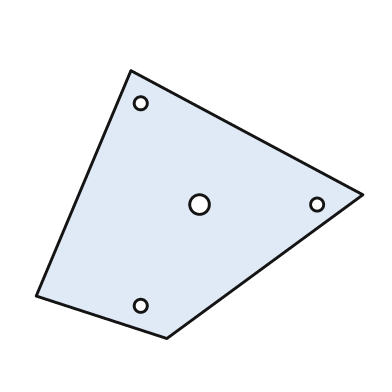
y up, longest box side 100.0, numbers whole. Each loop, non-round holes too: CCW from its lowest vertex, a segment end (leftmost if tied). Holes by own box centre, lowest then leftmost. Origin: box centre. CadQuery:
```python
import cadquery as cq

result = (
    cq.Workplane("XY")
    .moveTo(-10.0, -41.0)
    .lineTo(50.0, 3.0)
    .lineTo(-21.0, 41.0)
    .lineTo(-50.0, -28.0)
    .close()
    .moveTo(-18.0, -31.0)
    .circle(2.0)
    .moveTo(0.0, 0.0)
    .circle(3.0)
    .moveTo(36.0, 0.0)
    .circle(2.0)
    .moveTo(-18.0, 31.0)
    .circle(2.0)
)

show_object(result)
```